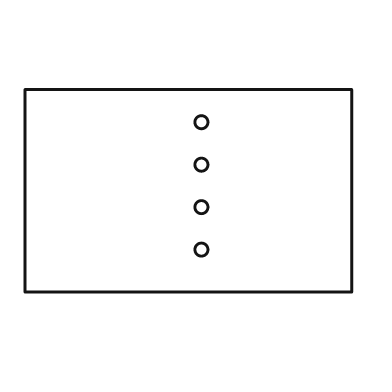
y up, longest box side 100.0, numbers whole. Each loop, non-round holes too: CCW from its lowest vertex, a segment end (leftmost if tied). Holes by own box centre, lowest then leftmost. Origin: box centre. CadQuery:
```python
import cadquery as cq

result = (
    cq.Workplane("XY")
    .moveTo(-50.0, -31.0)
    .lineTo(50.0, -31.0)
    .lineTo(50.0, 31.0)
    .lineTo(-50.0, 31.0)
    .close()
    .moveTo(4.0, -18.0)
    .circle(2.0)
    .moveTo(4.0, -5.0)
    .circle(2.0)
    .moveTo(4.0, 8.0)
    .circle(2.0)
    .moveTo(4.0, 21.0)
    .circle(2.0)
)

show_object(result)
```